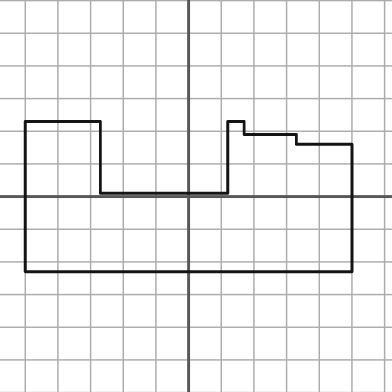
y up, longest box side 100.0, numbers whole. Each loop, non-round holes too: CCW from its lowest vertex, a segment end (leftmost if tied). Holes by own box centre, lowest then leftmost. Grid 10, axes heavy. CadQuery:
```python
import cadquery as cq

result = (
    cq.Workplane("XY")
    .moveTo(-50.0, -23.0)
    .lineTo(50.0, -23.0)
    .lineTo(50.0, 16.0)
    .lineTo(33.0, 16.0)
    .lineTo(33.0, 19.0)
    .lineTo(17.0, 19.0)
    .lineTo(17.0, 23.0)
    .lineTo(12.0, 23.0)
    .lineTo(12.0, 1.0)
    .lineTo(-27.0, 1.0)
    .lineTo(-27.0, 23.0)
    .lineTo(-50.0, 23.0)
    .close()
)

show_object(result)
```